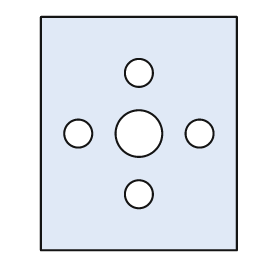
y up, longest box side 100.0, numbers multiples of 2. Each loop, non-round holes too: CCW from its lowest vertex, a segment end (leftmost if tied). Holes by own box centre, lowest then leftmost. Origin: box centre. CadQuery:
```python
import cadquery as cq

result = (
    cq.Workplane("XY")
    .moveTo(-42.0, -50.0)
    .lineTo(42.0, -50.0)
    .lineTo(42.0, 50.0)
    .lineTo(-42.0, 50.0)
    .close()
    .moveTo(0.0, -26.0)
    .circle(6.0)
    .moveTo(-26.0, 0.0)
    .circle(6.0)
    .moveTo(0.0, 0.0)
    .circle(10.0)
    .moveTo(26.0, 0.0)
    .circle(6.0)
    .moveTo(0.0, 26.0)
    .circle(6.0)
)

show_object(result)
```